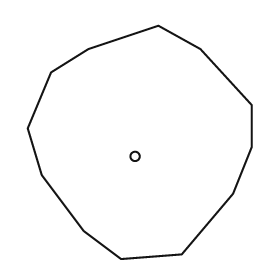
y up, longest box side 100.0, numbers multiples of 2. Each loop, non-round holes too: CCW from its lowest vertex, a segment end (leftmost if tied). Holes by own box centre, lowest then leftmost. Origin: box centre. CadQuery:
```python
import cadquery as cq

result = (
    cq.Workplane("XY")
    .moveTo(-8.0, -50.0)
    .lineTo(18.0, -48.0)
    .lineTo(40.0, -22.0)
    .lineTo(48.0, -2.0)
    .lineTo(48.0, 16.0)
    .lineTo(26.0, 40.0)
    .lineTo(8.0, 50.0)
    .lineTo(-22.0, 40.0)
    .lineTo(-38.0, 30.0)
    .lineTo(-48.0, 6.0)
    .lineTo(-42.0, -14.0)
    .lineTo(-24.0, -38.0)
    .close()
    .moveTo(-2.0, -6.0)
    .circle(2.0)
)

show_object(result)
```